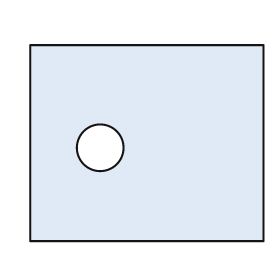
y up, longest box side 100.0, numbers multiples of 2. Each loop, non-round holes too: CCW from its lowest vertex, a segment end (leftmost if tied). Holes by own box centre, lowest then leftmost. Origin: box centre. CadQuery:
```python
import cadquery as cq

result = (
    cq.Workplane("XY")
    .moveTo(-50.0, -42.0)
    .lineTo(50.0, -42.0)
    .lineTo(50.0, 42.0)
    .lineTo(-50.0, 42.0)
    .close()
    .moveTo(-20.0, -2.0)
    .circle(10.0)
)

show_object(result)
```